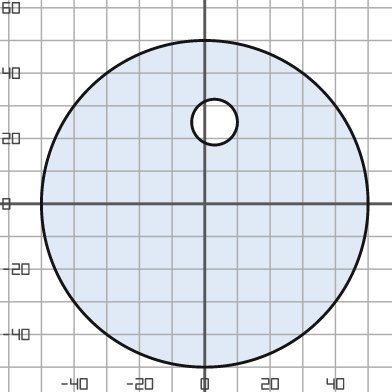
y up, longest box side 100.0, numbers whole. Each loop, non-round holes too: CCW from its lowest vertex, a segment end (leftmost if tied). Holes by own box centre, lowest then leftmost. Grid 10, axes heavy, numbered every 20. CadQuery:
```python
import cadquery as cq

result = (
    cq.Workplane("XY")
    .moveTo(0.0, 0.0)
    .circle(50.0)
    .moveTo(3.0, 25.0)
    .circle(7.0)
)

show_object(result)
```